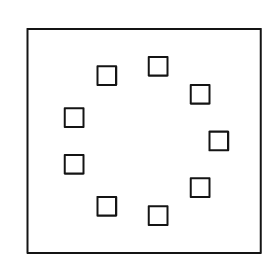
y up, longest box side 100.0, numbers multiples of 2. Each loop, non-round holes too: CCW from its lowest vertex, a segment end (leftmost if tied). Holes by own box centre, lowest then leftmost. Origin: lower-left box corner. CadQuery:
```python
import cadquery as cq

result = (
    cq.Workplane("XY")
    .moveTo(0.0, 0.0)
    .lineTo(100.0, 0.0)
    .lineTo(100.0, 96.0)
    .lineTo(0.0, 96.0)
    .close()
    .moveTo(52.0, 12.0)
    .lineTo(60.0, 12.0)
    .lineTo(60.0, 20.0)
    .lineTo(52.0, 20.0)
    .close()
    .moveTo(30.0, 16.0)
    .lineTo(38.0, 16.0)
    .lineTo(38.0, 24.0)
    .lineTo(30.0, 24.0)
    .close()
    .moveTo(70.0, 24.0)
    .lineTo(78.0, 24.0)
    .lineTo(78.0, 32.0)
    .lineTo(70.0, 32.0)
    .close()
    .moveTo(16.0, 34.0)
    .lineTo(24.0, 34.0)
    .lineTo(24.0, 42.0)
    .lineTo(16.0, 42.0)
    .close()
    .moveTo(78.0, 44.0)
    .lineTo(86.0, 44.0)
    .lineTo(86.0, 52.0)
    .lineTo(78.0, 52.0)
    .close()
    .moveTo(16.0, 54.0)
    .lineTo(24.0, 54.0)
    .lineTo(24.0, 62.0)
    .lineTo(16.0, 62.0)
    .close()
    .moveTo(70.0, 64.0)
    .lineTo(78.0, 64.0)
    .lineTo(78.0, 72.0)
    .lineTo(70.0, 72.0)
    .close()
    .moveTo(30.0, 72.0)
    .lineTo(38.0, 72.0)
    .lineTo(38.0, 80.0)
    .lineTo(30.0, 80.0)
    .close()
    .moveTo(52.0, 76.0)
    .lineTo(60.0, 76.0)
    .lineTo(60.0, 84.0)
    .lineTo(52.0, 84.0)
    .close()
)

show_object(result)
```